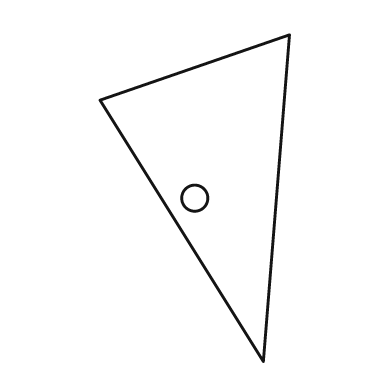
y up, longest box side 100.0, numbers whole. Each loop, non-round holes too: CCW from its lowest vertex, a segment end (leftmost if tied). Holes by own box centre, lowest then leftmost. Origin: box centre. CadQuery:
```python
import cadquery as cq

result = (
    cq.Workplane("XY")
    .moveTo(21.0, -50.0)
    .lineTo(29.0, 50.0)
    .lineTo(-29.0, 30.0)
    .close()
    .moveTo(0.0, 0.0)
    .circle(4.0)
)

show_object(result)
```